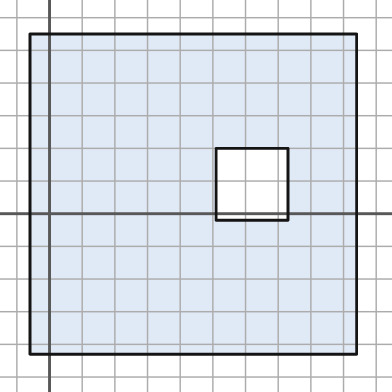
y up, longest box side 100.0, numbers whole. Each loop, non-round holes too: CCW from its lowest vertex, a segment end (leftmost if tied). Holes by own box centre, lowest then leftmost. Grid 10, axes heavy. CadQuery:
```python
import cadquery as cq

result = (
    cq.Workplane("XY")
    .moveTo(-6.0, -43.0)
    .lineTo(94.0, -43.0)
    .lineTo(94.0, 55.0)
    .lineTo(-6.0, 55.0)
    .close()
    .moveTo(51.0, -2.0)
    .lineTo(73.0, -2.0)
    .lineTo(73.0, 20.0)
    .lineTo(51.0, 20.0)
    .close()
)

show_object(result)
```